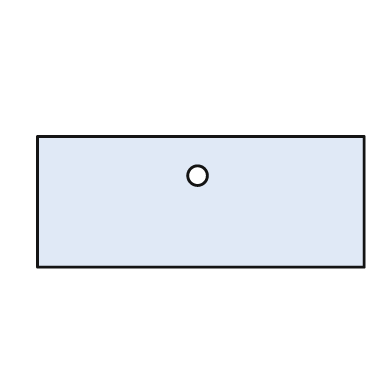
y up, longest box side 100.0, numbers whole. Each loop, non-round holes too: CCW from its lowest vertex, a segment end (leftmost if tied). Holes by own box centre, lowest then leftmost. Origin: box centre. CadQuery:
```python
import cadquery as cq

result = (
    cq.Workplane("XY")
    .moveTo(-50.0, -20.0)
    .lineTo(50.0, -20.0)
    .lineTo(50.0, 20.0)
    .lineTo(-50.0, 20.0)
    .close()
    .moveTo(-1.0, 8.0)
    .circle(3.0)
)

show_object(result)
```